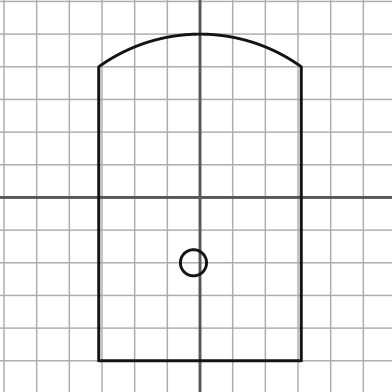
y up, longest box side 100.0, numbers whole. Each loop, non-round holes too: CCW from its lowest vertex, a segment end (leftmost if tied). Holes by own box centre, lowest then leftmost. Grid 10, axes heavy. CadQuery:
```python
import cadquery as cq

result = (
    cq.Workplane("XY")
    .moveTo(-31.0, -50.0)
    .lineTo(31.0, -50.0)
    .lineTo(31.0, 40.0)
    .threePointArc((0.0, 50.0), (-31.0, 40.0))
    .close()
    .moveTo(-2.0, -20.0)
    .circle(4.0)
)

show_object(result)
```